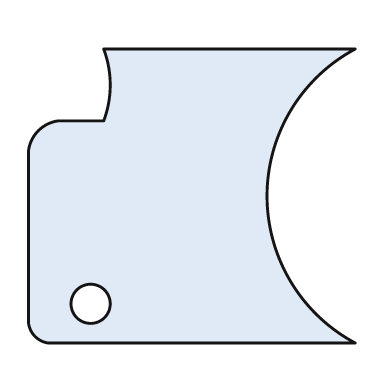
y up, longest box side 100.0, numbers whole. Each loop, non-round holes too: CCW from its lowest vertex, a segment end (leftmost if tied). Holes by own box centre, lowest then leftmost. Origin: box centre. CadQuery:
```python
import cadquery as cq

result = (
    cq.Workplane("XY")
    .moveTo(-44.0, -45.0)
    .lineTo(50.0, -45.0)
    .threePointArc((23.0, 0.0), (50.0, 45.0))
    .lineTo(-27.0, 45.0)
    .threePointArc((-25.0, 34.0), (-27.0, 23.0))
    .lineTo(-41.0, 23.0)
    .threePointArc((-47.0, 20.0), (-50.0, 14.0))
    .lineTo(-50.0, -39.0)
    .threePointArc((-48.0, -43.0), (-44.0, -45.0))
    .close()
    .moveTo(-31.0, -33.0)
    .circle(6.0)
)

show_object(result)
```